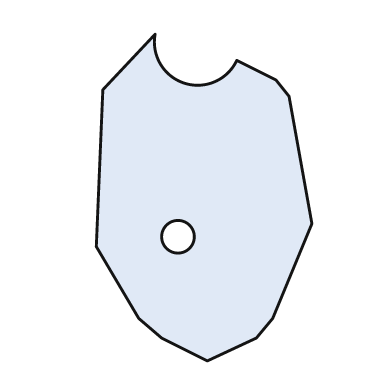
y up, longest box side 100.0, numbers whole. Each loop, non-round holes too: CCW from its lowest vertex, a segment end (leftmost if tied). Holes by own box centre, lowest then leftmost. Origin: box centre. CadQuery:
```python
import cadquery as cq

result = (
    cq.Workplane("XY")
    .moveTo(1.0, -50.0)
    .lineTo(16.0, -43.0)
    .lineTo(21.0, -37.0)
    .lineTo(33.0, -8.0)
    .lineTo(26.0, 31.0)
    .lineTo(22.0, 36.0)
    .lineTo(10.0, 42.0)
    .threePointArc((-6.0, 35.0), (-15.0, 50.0))
    .lineTo(-31.0, 33.0)
    .lineTo(-33.0, -15.0)
    .lineTo(-20.0, -37.0)
    .lineTo(-13.0, -43.0)
    .close()
    .moveTo(-8.0, -12.0)
    .circle(5.0)
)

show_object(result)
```